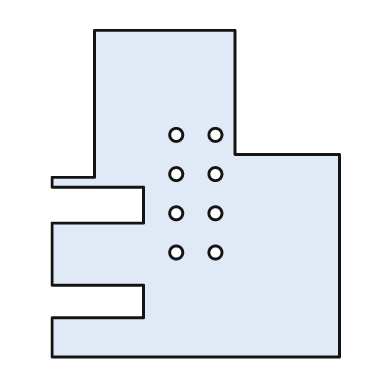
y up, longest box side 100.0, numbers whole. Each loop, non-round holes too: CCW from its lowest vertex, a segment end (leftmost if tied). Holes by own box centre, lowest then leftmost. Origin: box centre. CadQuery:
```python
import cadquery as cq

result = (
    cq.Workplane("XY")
    .moveTo(-44.0, -50.0)
    .lineTo(44.0, -50.0)
    .lineTo(44.0, 12.0)
    .lineTo(12.0, 12.0)
    .lineTo(12.0, 50.0)
    .lineTo(-31.0, 50.0)
    .lineTo(-31.0, 5.0)
    .lineTo(-44.0, 5.0)
    .lineTo(-44.0, 2.0)
    .lineTo(-16.0, 2.0)
    .lineTo(-16.0, -9.0)
    .lineTo(-44.0, -9.0)
    .lineTo(-44.0, -28.0)
    .lineTo(-16.0, -28.0)
    .lineTo(-16.0, -38.0)
    .lineTo(-44.0, -38.0)
    .close()
    .moveTo(-6.0, -18.0)
    .circle(2.0)
    .moveTo(6.0, -18.0)
    .circle(2.0)
    .moveTo(-6.0, -6.0)
    .circle(2.0)
    .moveTo(6.0, -6.0)
    .circle(2.0)
    .moveTo(-6.0, 6.0)
    .circle(2.0)
    .moveTo(6.0, 6.0)
    .circle(2.0)
    .moveTo(-6.0, 18.0)
    .circle(2.0)
    .moveTo(6.0, 18.0)
    .circle(2.0)
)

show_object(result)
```